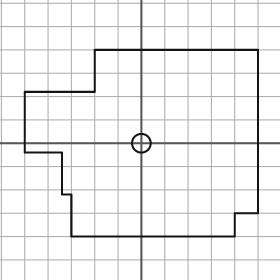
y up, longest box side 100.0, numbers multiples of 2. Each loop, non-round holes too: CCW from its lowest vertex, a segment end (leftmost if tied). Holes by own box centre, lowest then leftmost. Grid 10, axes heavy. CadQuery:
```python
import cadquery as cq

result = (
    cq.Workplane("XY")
    .moveTo(-30.0, -40.0)
    .lineTo(40.0, -40.0)
    .lineTo(40.0, -30.0)
    .lineTo(50.0, -30.0)
    .lineTo(50.0, 40.0)
    .lineTo(-20.0, 40.0)
    .lineTo(-20.0, 22.0)
    .lineTo(-50.0, 22.0)
    .lineTo(-50.0, -4.0)
    .lineTo(-34.0, -4.0)
    .lineTo(-34.0, -22.0)
    .lineTo(-30.0, -22.0)
    .close()
    .moveTo(0.0, 0.0)
    .circle(4.0)
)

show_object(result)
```